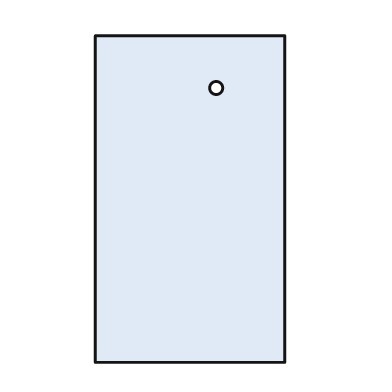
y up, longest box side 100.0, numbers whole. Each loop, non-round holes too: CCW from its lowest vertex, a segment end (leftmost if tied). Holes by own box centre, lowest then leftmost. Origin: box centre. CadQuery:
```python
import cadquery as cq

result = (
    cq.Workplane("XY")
    .moveTo(-29.0, -50.0)
    .lineTo(29.0, -50.0)
    .lineTo(29.0, 50.0)
    .lineTo(-29.0, 50.0)
    .close()
    .moveTo(8.0, 34.0)
    .circle(2.0)
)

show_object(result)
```